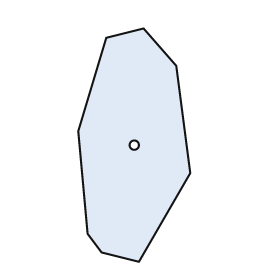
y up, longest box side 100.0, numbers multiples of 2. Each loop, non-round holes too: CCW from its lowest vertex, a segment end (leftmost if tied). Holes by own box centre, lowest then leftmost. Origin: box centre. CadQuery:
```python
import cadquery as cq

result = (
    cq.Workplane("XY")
    .moveTo(2.0, -50.0)
    .lineTo(24.0, -12.0)
    .lineTo(18.0, 34.0)
    .lineTo(4.0, 50.0)
    .lineTo(-12.0, 46.0)
    .lineTo(-24.0, 6.0)
    .lineTo(-20.0, -38.0)
    .lineTo(-14.0, -46.0)
    .close()
    .moveTo(0.0, 0.0)
    .circle(2.0)
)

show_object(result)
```